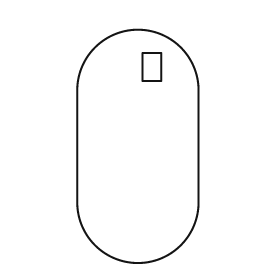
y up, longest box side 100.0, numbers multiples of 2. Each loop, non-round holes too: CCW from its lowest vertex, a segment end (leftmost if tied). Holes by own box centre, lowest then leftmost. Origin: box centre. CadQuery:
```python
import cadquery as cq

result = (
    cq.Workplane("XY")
    .moveTo(-26.0, -24.0)
    .threePointArc((0.0, -50.0), (26.0, -24.0))
    .lineTo(26.0, 24.0)
    .threePointArc((0.0, 50.0), (-26.0, 24.0))
    .close()
    .moveTo(2.0, 28.0)
    .lineTo(10.0, 28.0)
    .lineTo(10.0, 40.0)
    .lineTo(2.0, 40.0)
    .close()
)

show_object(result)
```